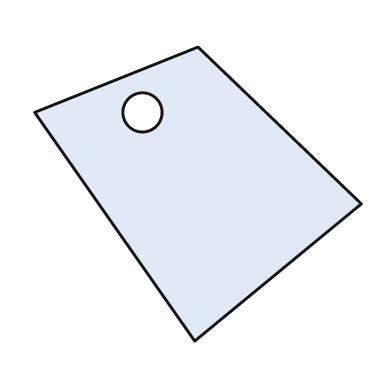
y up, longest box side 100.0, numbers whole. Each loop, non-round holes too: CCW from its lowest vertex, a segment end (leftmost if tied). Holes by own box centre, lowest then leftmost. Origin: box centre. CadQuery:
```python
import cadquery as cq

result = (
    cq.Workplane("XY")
    .moveTo(-1.0, -45.0)
    .lineTo(50.0, -3.0)
    .lineTo(0.0, 45.0)
    .lineTo(-50.0, 25.0)
    .close()
    .moveTo(-17.0, 25.0)
    .circle(6.0)
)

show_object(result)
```